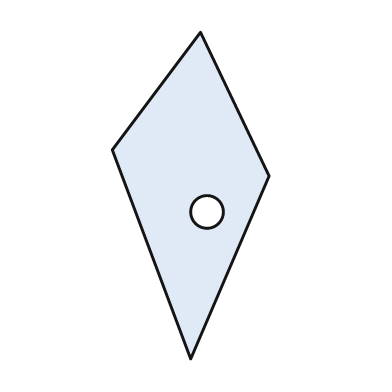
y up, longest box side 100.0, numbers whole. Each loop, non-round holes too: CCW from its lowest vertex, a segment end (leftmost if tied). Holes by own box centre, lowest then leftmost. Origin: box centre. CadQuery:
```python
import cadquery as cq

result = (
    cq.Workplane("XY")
    .moveTo(0.0, -50.0)
    .lineTo(24.0, 6.0)
    .lineTo(3.0, 50.0)
    .lineTo(-24.0, 14.0)
    .close()
    .moveTo(5.0, -5.0)
    .circle(5.0)
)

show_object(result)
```